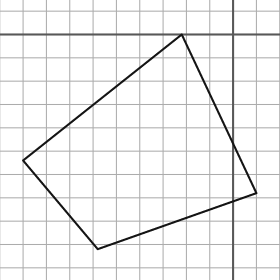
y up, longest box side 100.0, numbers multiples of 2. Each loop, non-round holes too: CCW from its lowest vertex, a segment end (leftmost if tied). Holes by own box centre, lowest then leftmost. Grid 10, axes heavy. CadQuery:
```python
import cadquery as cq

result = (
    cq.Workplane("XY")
    .moveTo(-58.0, -92.0)
    .lineTo(10.0, -68.0)
    .lineTo(-22.0, 0.0)
    .lineTo(-90.0, -54.0)
    .close()
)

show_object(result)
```